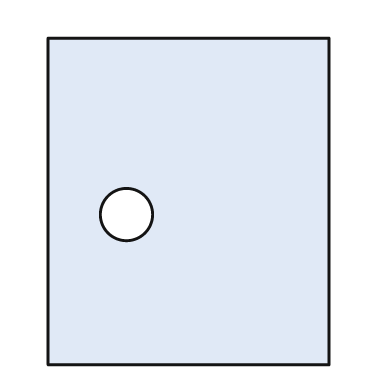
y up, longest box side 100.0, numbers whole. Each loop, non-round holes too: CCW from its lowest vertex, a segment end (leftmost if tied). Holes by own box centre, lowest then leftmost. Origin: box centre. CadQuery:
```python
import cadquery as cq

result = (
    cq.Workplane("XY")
    .moveTo(-43.0, -50.0)
    .lineTo(43.0, -50.0)
    .lineTo(43.0, 50.0)
    .lineTo(-43.0, 50.0)
    .close()
    .moveTo(-19.0, -4.0)
    .circle(8.0)
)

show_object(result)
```